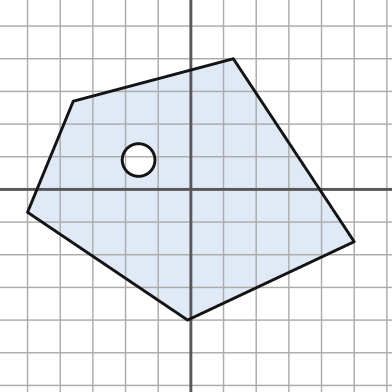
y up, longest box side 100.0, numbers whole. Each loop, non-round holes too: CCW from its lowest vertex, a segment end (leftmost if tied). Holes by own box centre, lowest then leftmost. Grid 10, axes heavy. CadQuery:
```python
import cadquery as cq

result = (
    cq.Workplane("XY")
    .moveTo(-1.0, -40.0)
    .lineTo(50.0, -16.0)
    .lineTo(13.0, 40.0)
    .lineTo(-36.0, 27.0)
    .lineTo(-50.0, -7.0)
    .close()
    .moveTo(-16.0, 9.0)
    .circle(5.0)
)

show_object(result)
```